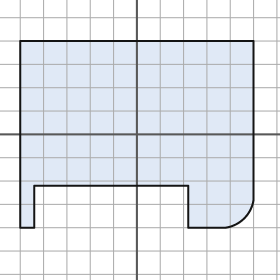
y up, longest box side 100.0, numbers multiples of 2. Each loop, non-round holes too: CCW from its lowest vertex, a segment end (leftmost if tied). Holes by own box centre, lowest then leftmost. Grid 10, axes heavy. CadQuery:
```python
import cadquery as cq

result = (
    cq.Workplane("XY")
    .moveTo(-50.0, -40.0)
    .lineTo(-44.0, -40.0)
    .lineTo(-44.0, -22.0)
    .lineTo(22.0, -22.0)
    .lineTo(22.0, -40.0)
    .lineTo(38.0, -40.0)
    .threePointArc((46.0, -36.0), (50.0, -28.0))
    .lineTo(50.0, 40.0)
    .lineTo(-50.0, 40.0)
    .close()
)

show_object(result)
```